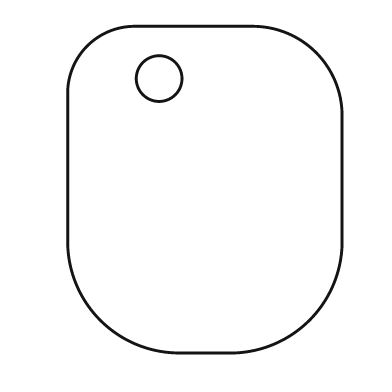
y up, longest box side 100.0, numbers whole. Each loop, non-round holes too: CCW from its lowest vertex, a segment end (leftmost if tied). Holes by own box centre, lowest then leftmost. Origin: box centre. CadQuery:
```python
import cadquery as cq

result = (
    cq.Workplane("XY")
    .moveTo(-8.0, -50.0)
    .lineTo(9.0, -50.0)
    .threePointArc((32.0, -40.0), (42.0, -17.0))
    .lineTo(42.0, 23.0)
    .threePointArc((34.0, 42.0), (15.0, 50.0))
    .lineTo(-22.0, 50.0)
    .threePointArc((-36.0, 44.0), (-42.0, 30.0))
    .lineTo(-42.0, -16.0)
    .threePointArc((-32.0, -40.0), (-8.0, -50.0))
    .close()
    .moveTo(-14.0, 34.0)
    .circle(7.0)
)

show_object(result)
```